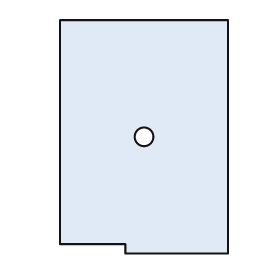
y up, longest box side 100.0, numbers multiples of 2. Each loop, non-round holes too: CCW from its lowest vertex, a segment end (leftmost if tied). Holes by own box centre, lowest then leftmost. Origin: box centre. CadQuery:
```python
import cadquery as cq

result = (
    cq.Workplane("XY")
    .moveTo(-8.0, -50.0)
    .lineTo(36.0, -50.0)
    .lineTo(36.0, 50.0)
    .lineTo(-36.0, 50.0)
    .lineTo(-36.0, -46.0)
    .lineTo(-8.0, -46.0)
    .close()
    .moveTo(0.0, 0.0)
    .circle(4.0)
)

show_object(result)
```